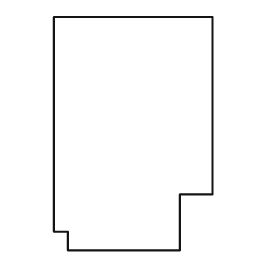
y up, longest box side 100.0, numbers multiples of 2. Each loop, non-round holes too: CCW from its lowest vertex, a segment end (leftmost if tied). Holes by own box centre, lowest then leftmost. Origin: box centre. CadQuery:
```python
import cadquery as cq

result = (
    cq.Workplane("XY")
    .moveTo(-28.0, -50.0)
    .lineTo(20.0, -50.0)
    .lineTo(20.0, -26.0)
    .lineTo(34.0, -26.0)
    .lineTo(34.0, 50.0)
    .lineTo(-34.0, 50.0)
    .lineTo(-34.0, -42.0)
    .lineTo(-28.0, -42.0)
    .close()
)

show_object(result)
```